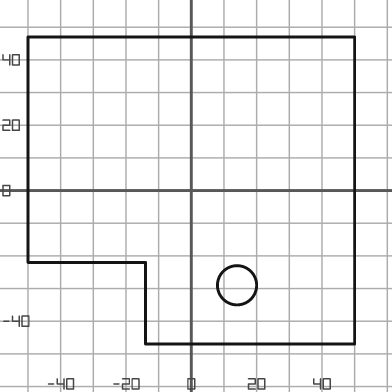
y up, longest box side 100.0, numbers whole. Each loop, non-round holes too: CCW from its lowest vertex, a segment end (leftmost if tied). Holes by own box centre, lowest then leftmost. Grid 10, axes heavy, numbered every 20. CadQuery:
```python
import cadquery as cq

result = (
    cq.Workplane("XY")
    .moveTo(-14.0, -47.0)
    .lineTo(50.0, -47.0)
    .lineTo(50.0, 47.0)
    .lineTo(-50.0, 47.0)
    .lineTo(-50.0, -22.0)
    .lineTo(-14.0, -22.0)
    .close()
    .moveTo(14.0, -29.0)
    .circle(6.0)
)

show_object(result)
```